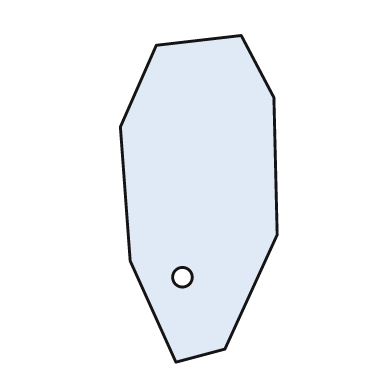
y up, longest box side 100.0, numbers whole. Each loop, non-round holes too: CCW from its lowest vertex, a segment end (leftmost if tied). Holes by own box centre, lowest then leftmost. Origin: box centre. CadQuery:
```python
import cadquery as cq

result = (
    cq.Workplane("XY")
    .moveTo(-7.0, -50.0)
    .lineTo(8.0, -46.0)
    .lineTo(24.0, -11.0)
    .lineTo(23.0, 31.0)
    .lineTo(13.0, 50.0)
    .lineTo(-13.0, 47.0)
    .lineTo(-24.0, 22.0)
    .lineTo(-21.0, -19.0)
    .close()
    .moveTo(-5.0, -24.0)
    .circle(3.0)
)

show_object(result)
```